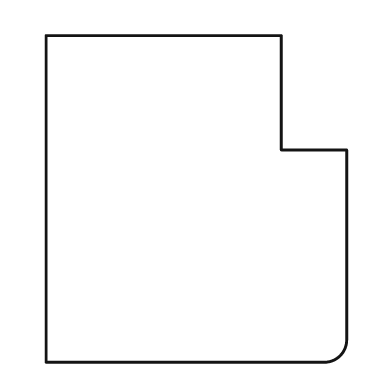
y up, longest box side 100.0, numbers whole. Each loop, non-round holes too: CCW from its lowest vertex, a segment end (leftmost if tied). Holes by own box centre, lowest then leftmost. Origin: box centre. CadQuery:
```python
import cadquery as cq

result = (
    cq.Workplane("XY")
    .moveTo(-46.0, -50.0)
    .lineTo(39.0, -50.0)
    .threePointArc((44.0, -48.0), (46.0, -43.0))
    .lineTo(46.0, 15.0)
    .lineTo(26.0, 15.0)
    .lineTo(26.0, 50.0)
    .lineTo(-46.0, 50.0)
    .close()
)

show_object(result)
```